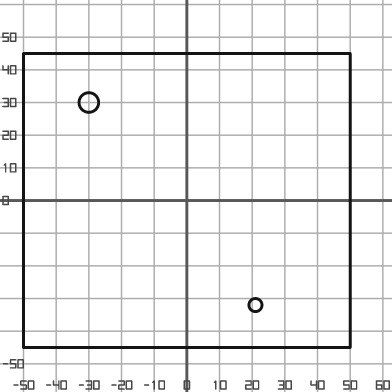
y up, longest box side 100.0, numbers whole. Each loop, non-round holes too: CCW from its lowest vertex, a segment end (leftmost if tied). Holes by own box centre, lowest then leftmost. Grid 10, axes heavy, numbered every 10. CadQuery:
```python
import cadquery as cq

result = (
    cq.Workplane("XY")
    .moveTo(-50.0, -45.0)
    .lineTo(50.0, -45.0)
    .lineTo(50.0, 45.0)
    .lineTo(-50.0, 45.0)
    .close()
    .moveTo(21.0, -32.0)
    .circle(2.0)
    .moveTo(-30.0, 30.0)
    .circle(3.0)
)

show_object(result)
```